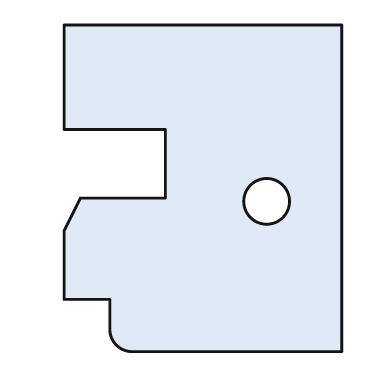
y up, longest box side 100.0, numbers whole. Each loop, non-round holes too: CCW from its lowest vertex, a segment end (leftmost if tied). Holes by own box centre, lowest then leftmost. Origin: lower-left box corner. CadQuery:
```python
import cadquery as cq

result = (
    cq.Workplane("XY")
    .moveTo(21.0, 0.0)
    .lineTo(85.0, 0.0)
    .lineTo(85.0, 100.0)
    .lineTo(0.0, 100.0)
    .lineTo(0.0, 68.0)
    .lineTo(31.0, 68.0)
    .lineTo(31.0, 47.0)
    .lineTo(5.0, 47.0)
    .lineTo(0.0, 37.0)
    .lineTo(0.0, 16.0)
    .lineTo(14.0, 16.0)
    .lineTo(14.0, 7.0)
    .threePointArc((16.0, 2.0), (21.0, 0.0))
    .close()
    .moveTo(62.0, 46.0)
    .circle(7.0)
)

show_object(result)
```